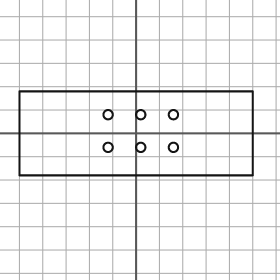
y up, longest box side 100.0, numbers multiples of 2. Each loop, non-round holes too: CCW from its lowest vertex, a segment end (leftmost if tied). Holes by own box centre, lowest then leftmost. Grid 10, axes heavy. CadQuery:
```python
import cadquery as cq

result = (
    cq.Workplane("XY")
    .moveTo(-50.0, -18.0)
    .lineTo(50.0, -18.0)
    .lineTo(50.0, 18.0)
    .lineTo(-50.0, 18.0)
    .close()
    .moveTo(-12.0, -6.0)
    .circle(2.0)
    .moveTo(2.0, -6.0)
    .circle(2.0)
    .moveTo(16.0, -6.0)
    .circle(2.0)
    .moveTo(-12.0, 8.0)
    .circle(2.0)
    .moveTo(2.0, 8.0)
    .circle(2.0)
    .moveTo(16.0, 8.0)
    .circle(2.0)
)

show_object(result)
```